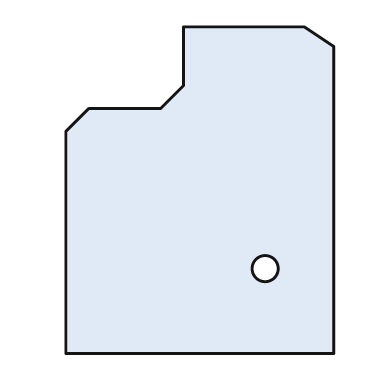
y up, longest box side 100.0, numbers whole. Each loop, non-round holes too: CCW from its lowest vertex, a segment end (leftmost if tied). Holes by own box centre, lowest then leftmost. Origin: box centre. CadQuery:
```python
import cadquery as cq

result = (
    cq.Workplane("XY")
    .moveTo(-41.0, -50.0)
    .lineTo(41.0, -50.0)
    .lineTo(41.0, 44.0)
    .lineTo(32.0, 50.0)
    .lineTo(-5.0, 50.0)
    .lineTo(-5.0, 32.0)
    .lineTo(-12.0, 25.0)
    .lineTo(-34.0, 25.0)
    .lineTo(-41.0, 18.0)
    .close()
    .moveTo(20.0, -24.0)
    .circle(4.0)
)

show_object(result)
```